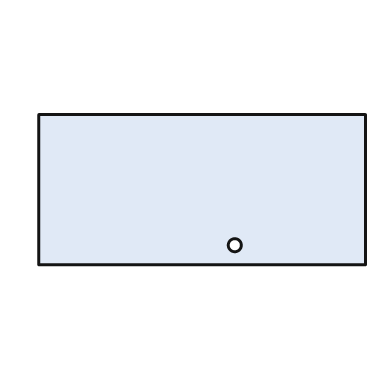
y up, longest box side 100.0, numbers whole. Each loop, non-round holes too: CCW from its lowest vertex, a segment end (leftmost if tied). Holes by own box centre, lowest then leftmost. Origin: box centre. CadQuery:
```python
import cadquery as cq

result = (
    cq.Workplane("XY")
    .moveTo(-50.0, -23.0)
    .lineTo(50.0, -23.0)
    .lineTo(50.0, 23.0)
    .lineTo(-50.0, 23.0)
    .close()
    .moveTo(10.0, -17.0)
    .circle(2.0)
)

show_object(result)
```